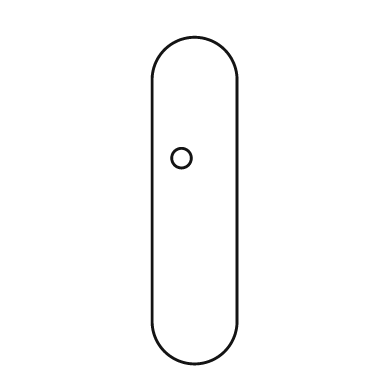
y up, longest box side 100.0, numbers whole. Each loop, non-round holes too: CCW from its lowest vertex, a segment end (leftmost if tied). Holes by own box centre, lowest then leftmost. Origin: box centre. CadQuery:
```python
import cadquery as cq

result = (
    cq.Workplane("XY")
    .moveTo(-13.0, -37.0)
    .threePointArc((0.0, -50.0), (13.0, -37.0))
    .lineTo(13.0, 37.0)
    .threePointArc((0.0, 50.0), (-13.0, 37.0))
    .close()
    .moveTo(-4.0, 13.0)
    .circle(3.0)
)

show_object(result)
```